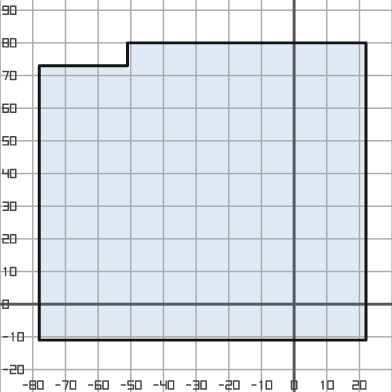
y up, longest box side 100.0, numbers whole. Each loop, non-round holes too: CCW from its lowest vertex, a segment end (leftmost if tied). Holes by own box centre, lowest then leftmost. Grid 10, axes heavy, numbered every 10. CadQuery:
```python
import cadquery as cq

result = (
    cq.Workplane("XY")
    .moveTo(-78.0, -11.0)
    .lineTo(22.0, -11.0)
    .lineTo(22.0, 80.0)
    .lineTo(-51.0, 80.0)
    .lineTo(-51.0, 73.0)
    .lineTo(-78.0, 73.0)
    .close()
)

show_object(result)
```